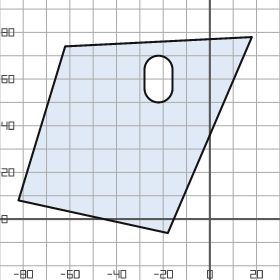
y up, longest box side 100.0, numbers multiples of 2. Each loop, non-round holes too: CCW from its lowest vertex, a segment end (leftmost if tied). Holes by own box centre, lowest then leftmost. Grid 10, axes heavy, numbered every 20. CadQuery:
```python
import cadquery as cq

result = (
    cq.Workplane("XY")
    .moveTo(-18.0, -6.0)
    .lineTo(18.0, 78.0)
    .lineTo(-62.0, 74.0)
    .lineTo(-82.0, 8.0)
    .close()
    .moveTo(-28.0, 56.0)
    .threePointArc((-22.0, 50.0), (-16.0, 56.0))
    .lineTo(-16.0, 64.0)
    .threePointArc((-22.0, 70.0), (-28.0, 64.0))
    .close()
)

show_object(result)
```